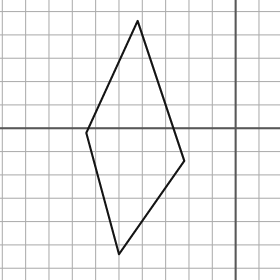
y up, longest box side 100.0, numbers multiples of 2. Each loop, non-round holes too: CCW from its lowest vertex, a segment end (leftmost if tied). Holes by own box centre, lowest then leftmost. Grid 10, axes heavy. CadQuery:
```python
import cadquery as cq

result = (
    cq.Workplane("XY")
    .moveTo(-50.0, -54.0)
    .lineTo(-22.0, -14.0)
    .lineTo(-42.0, 46.0)
    .lineTo(-64.0, -2.0)
    .close()
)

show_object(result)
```